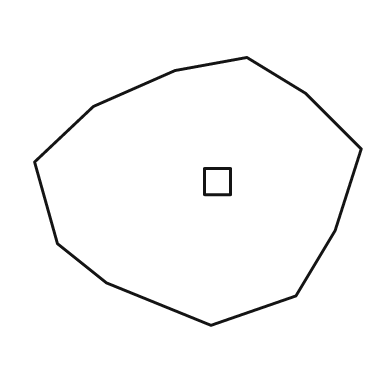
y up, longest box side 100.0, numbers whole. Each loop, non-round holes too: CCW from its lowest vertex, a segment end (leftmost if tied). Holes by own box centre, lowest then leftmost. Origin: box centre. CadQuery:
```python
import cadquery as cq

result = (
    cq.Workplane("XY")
    .moveTo(4.0, -41.0)
    .lineTo(30.0, -32.0)
    .lineTo(42.0, -12.0)
    .lineTo(50.0, 13.0)
    .lineTo(33.0, 30.0)
    .lineTo(15.0, 41.0)
    .lineTo(-7.0, 37.0)
    .lineTo(-32.0, 26.0)
    .lineTo(-50.0, 9.0)
    .lineTo(-43.0, -16.0)
    .lineTo(-28.0, -28.0)
    .close()
    .moveTo(2.0, -1.0)
    .lineTo(10.0, -1.0)
    .lineTo(10.0, 7.0)
    .lineTo(2.0, 7.0)
    .close()
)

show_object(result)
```